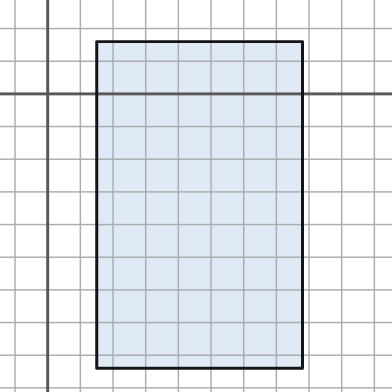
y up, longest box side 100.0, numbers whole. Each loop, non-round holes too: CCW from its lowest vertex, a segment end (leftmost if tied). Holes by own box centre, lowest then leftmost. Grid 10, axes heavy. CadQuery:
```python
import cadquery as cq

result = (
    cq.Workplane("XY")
    .moveTo(15.0, -84.0)
    .lineTo(78.0, -84.0)
    .lineTo(78.0, 16.0)
    .lineTo(15.0, 16.0)
    .close()
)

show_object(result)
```